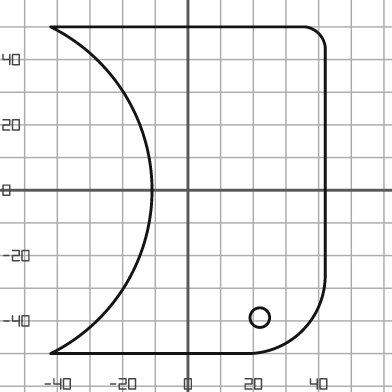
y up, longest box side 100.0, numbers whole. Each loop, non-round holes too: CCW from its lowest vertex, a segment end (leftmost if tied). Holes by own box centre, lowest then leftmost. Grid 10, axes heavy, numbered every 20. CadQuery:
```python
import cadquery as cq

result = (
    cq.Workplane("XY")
    .moveTo(-42.0, -50.0)
    .lineTo(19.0, -50.0)
    .threePointArc((35.0, -43.0), (42.0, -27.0))
    .lineTo(42.0, 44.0)
    .threePointArc((40.0, 48.0), (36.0, 50.0))
    .lineTo(-42.0, 50.0)
    .threePointArc((-11.0, 0.0), (-42.0, -50.0))
    .close()
    .moveTo(22.0, -39.0)
    .circle(3.0)
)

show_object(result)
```